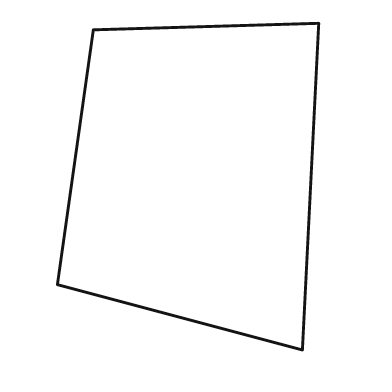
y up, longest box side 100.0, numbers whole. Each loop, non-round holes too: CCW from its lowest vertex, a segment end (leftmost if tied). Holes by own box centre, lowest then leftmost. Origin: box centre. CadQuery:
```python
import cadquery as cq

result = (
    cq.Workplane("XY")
    .moveTo(35.0, -50.0)
    .lineTo(40.0, 50.0)
    .lineTo(-29.0, 48.0)
    .lineTo(-40.0, -30.0)
    .close()
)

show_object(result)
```